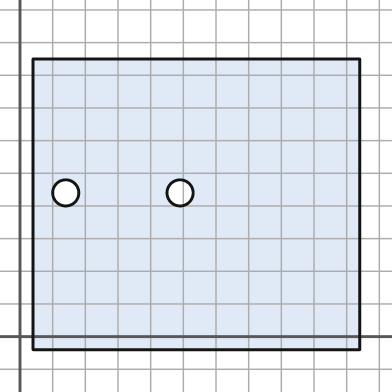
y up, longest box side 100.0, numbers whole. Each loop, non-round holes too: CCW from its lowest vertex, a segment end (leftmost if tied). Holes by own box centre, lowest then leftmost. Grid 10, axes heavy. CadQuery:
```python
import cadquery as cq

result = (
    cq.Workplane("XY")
    .moveTo(4.0, -4.0)
    .lineTo(104.0, -4.0)
    .lineTo(104.0, 85.0)
    .lineTo(4.0, 85.0)
    .close()
    .moveTo(14.0, 44.0)
    .circle(4.0)
    .moveTo(49.0, 44.0)
    .circle(4.0)
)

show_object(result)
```